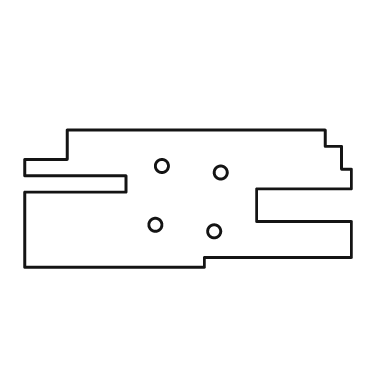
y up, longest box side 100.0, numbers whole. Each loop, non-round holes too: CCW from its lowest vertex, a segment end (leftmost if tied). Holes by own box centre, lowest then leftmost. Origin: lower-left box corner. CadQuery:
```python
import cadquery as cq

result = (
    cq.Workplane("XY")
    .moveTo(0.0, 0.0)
    .lineTo(55.0, 0.0)
    .lineTo(55.0, 3.0)
    .lineTo(100.0, 3.0)
    .lineTo(100.0, 14.0)
    .lineTo(71.0, 14.0)
    .lineTo(71.0, 24.0)
    .lineTo(100.0, 24.0)
    .lineTo(100.0, 30.0)
    .lineTo(97.0, 30.0)
    .lineTo(97.0, 37.0)
    .lineTo(92.0, 37.0)
    .lineTo(92.0, 42.0)
    .lineTo(13.0, 42.0)
    .lineTo(13.0, 33.0)
    .lineTo(0.0, 33.0)
    .lineTo(0.0, 28.0)
    .lineTo(31.0, 28.0)
    .lineTo(31.0, 23.0)
    .lineTo(0.0, 23.0)
    .close()
    .moveTo(58.0, 11.0)
    .circle(2.0)
    .moveTo(40.0, 13.0)
    .circle(2.0)
    .moveTo(60.0, 29.0)
    .circle(2.0)
    .moveTo(42.0, 31.0)
    .circle(2.0)
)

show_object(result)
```